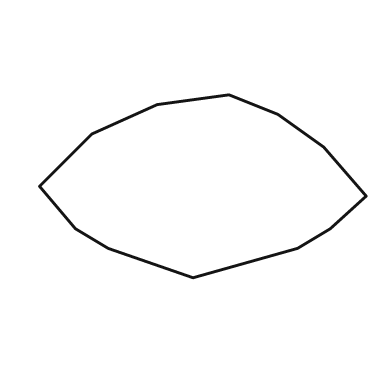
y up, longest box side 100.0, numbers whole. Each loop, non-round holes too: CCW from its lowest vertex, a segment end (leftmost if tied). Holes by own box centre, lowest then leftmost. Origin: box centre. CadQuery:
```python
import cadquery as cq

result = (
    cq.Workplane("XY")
    .moveTo(-3.0, -28.0)
    .lineTo(29.0, -19.0)
    .lineTo(39.0, -13.0)
    .lineTo(50.0, -3.0)
    .lineTo(37.0, 12.0)
    .lineTo(23.0, 22.0)
    .lineTo(8.0, 28.0)
    .lineTo(-14.0, 25.0)
    .lineTo(-34.0, 16.0)
    .lineTo(-50.0, 0.0)
    .lineTo(-39.0, -13.0)
    .lineTo(-29.0, -19.0)
    .close()
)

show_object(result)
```